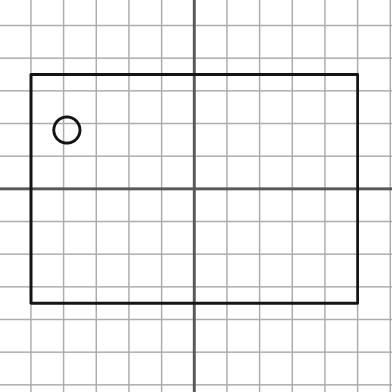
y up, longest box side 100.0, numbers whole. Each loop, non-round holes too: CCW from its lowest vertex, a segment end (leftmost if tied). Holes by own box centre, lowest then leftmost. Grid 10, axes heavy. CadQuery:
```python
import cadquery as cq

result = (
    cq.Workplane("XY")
    .moveTo(-50.0, -35.0)
    .lineTo(50.0, -35.0)
    .lineTo(50.0, 35.0)
    .lineTo(-50.0, 35.0)
    .close()
    .moveTo(-39.0, 18.0)
    .circle(4.0)
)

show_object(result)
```